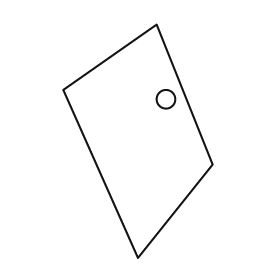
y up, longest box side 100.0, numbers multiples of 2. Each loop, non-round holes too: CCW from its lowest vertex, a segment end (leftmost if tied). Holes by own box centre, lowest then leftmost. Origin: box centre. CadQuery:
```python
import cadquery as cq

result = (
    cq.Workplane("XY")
    .moveTo(0.0, -50.0)
    .lineTo(32.0, -10.0)
    .lineTo(8.0, 50.0)
    .lineTo(-32.0, 22.0)
    .close()
    .moveTo(12.0, 18.0)
    .circle(4.0)
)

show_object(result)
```